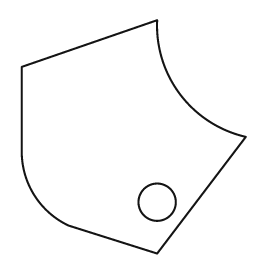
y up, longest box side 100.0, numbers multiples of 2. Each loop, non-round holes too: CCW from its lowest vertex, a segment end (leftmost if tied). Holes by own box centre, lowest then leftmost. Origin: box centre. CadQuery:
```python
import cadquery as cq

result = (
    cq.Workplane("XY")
    .moveTo(10.0, -50.0)
    .lineTo(48.0, 0.0)
    .threePointArc((20.0, 18.0), (10.0, 50.0))
    .lineTo(-48.0, 30.0)
    .lineTo(-48.0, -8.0)
    .threePointArc((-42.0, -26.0), (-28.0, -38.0))
    .close()
    .moveTo(10.0, -28.0)
    .circle(8.0)
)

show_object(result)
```